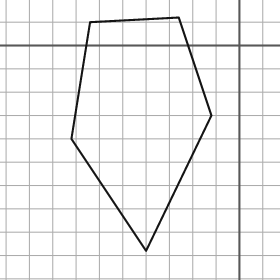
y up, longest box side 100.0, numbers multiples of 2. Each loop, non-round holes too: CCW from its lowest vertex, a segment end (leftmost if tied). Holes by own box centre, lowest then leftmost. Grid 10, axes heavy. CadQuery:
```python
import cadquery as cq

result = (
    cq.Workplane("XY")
    .moveTo(-40.0, -88.0)
    .lineTo(-12.0, -30.0)
    .lineTo(-26.0, 12.0)
    .lineTo(-64.0, 10.0)
    .lineTo(-72.0, -40.0)
    .close()
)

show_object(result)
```